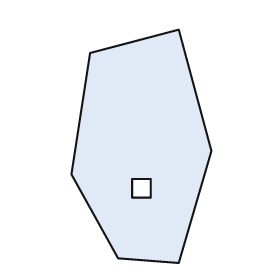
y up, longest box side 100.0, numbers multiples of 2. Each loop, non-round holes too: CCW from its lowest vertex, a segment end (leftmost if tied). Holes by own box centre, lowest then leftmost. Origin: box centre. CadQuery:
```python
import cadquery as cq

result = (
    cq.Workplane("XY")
    .moveTo(16.0, -50.0)
    .lineTo(30.0, -2.0)
    .lineTo(16.0, 50.0)
    .lineTo(-22.0, 40.0)
    .lineTo(-30.0, -12.0)
    .lineTo(-10.0, -48.0)
    .close()
    .moveTo(-4.0, -22.0)
    .lineTo(4.0, -22.0)
    .lineTo(4.0, -14.0)
    .lineTo(-4.0, -14.0)
    .close()
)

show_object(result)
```